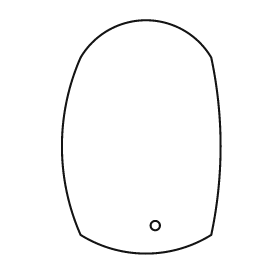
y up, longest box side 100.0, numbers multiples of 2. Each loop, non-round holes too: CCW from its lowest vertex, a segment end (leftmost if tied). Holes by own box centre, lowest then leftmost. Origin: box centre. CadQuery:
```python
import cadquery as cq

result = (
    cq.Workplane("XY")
    .moveTo(-26.0, -42.0)
    .threePointArc((2.0, -50.0), (30.0, -42.0))
    .threePointArc((34.0, -4.0), (30.0, 34.0))
    .threePointArc((2.0, 50.0), (-26.0, 34.0))
    .threePointArc((-34.0, -4.0), (-26.0, -42.0))
    .close()
    .moveTo(6.0, -38.0)
    .circle(2.0)
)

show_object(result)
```